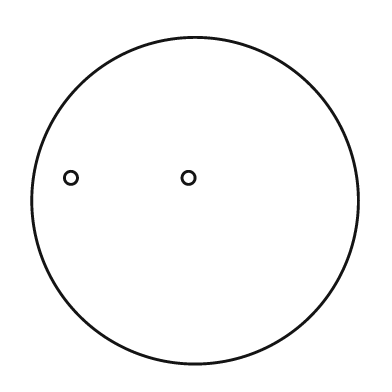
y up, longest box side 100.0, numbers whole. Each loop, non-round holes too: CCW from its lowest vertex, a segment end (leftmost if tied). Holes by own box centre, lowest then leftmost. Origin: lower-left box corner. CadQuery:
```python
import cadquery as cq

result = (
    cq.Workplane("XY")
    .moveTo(50.0, 50.0)
    .circle(50.0)
    .moveTo(12.0, 57.0)
    .circle(2.0)
    .moveTo(48.0, 57.0)
    .circle(2.0)
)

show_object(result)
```